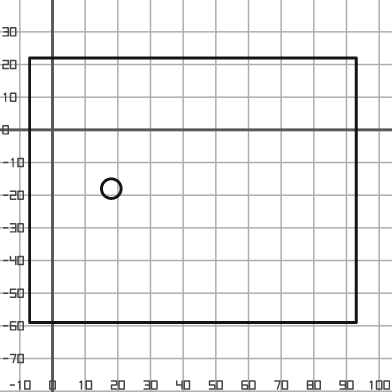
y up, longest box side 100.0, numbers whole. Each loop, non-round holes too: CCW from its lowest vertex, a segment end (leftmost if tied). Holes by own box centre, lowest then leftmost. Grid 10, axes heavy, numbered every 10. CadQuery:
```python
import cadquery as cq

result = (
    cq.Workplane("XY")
    .moveTo(-7.0, -59.0)
    .lineTo(93.0, -59.0)
    .lineTo(93.0, 22.0)
    .lineTo(-7.0, 22.0)
    .close()
    .moveTo(18.0, -18.0)
    .circle(3.0)
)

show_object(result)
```